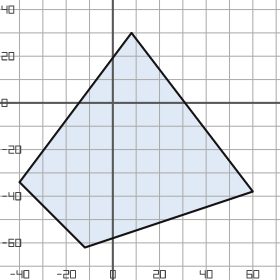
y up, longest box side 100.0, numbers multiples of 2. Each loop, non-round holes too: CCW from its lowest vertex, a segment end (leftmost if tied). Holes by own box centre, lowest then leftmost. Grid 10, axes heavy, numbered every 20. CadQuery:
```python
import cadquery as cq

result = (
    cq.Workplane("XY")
    .moveTo(-12.0, -62.0)
    .lineTo(60.0, -38.0)
    .lineTo(8.0, 30.0)
    .lineTo(-40.0, -34.0)
    .close()
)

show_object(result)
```